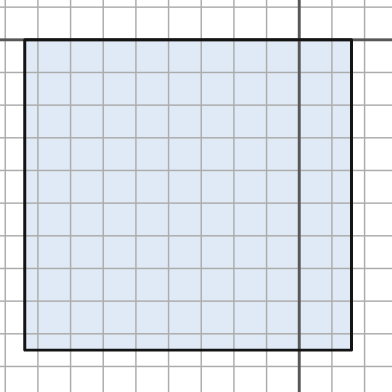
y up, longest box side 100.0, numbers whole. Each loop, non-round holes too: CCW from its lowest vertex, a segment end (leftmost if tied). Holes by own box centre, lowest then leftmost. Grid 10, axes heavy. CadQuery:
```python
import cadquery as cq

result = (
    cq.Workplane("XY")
    .moveTo(-84.0, -95.0)
    .lineTo(16.0, -95.0)
    .lineTo(16.0, 0.0)
    .lineTo(-84.0, 0.0)
    .close()
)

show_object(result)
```